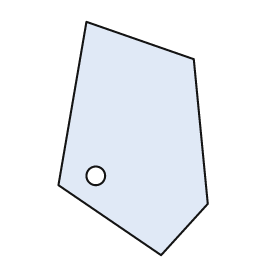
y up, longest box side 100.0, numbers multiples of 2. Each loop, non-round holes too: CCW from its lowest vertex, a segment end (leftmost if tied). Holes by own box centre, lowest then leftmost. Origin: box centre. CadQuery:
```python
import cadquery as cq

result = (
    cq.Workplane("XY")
    .moveTo(12.0, -50.0)
    .lineTo(32.0, -28.0)
    .lineTo(26.0, 34.0)
    .lineTo(-20.0, 50.0)
    .lineTo(-32.0, -20.0)
    .close()
    .moveTo(-16.0, -16.0)
    .circle(4.0)
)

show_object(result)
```